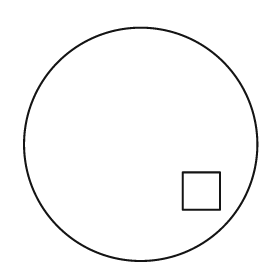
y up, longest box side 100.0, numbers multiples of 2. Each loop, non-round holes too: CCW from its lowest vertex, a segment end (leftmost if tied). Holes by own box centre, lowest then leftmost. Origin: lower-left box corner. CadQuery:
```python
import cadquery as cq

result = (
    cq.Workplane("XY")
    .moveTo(50.0, 50.0)
    .circle(50.0)
    .moveTo(68.0, 22.0)
    .lineTo(84.0, 22.0)
    .lineTo(84.0, 38.0)
    .lineTo(68.0, 38.0)
    .close()
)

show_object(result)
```